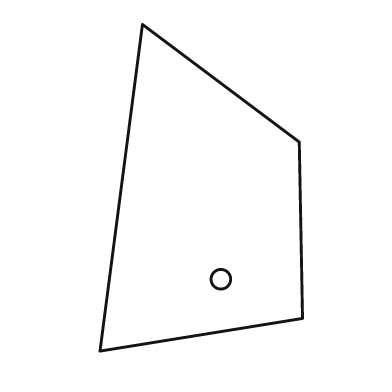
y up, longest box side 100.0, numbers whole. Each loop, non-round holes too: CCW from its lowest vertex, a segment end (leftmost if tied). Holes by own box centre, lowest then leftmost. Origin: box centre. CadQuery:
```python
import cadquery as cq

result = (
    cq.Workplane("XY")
    .moveTo(-31.0, -50.0)
    .lineTo(31.0, -40.0)
    .lineTo(30.0, 14.0)
    .lineTo(-18.0, 50.0)
    .close()
    .moveTo(6.0, -28.0)
    .circle(3.0)
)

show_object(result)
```